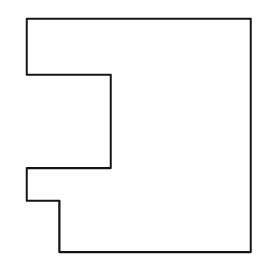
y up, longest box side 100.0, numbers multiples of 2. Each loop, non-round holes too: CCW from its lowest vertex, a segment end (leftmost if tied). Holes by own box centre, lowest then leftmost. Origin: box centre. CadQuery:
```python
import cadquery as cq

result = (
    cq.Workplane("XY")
    .moveTo(-34.0, -50.0)
    .lineTo(48.0, -50.0)
    .lineTo(48.0, 50.0)
    .lineTo(-48.0, 50.0)
    .lineTo(-48.0, 26.0)
    .lineTo(-12.0, 26.0)
    .lineTo(-12.0, -14.0)
    .lineTo(-48.0, -14.0)
    .lineTo(-48.0, -28.0)
    .lineTo(-34.0, -28.0)
    .close()
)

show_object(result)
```